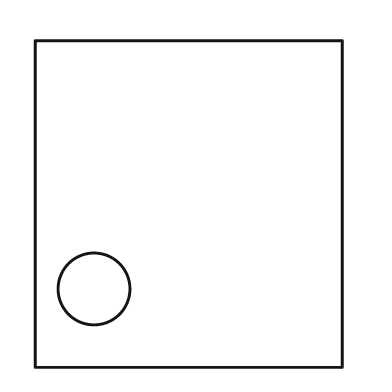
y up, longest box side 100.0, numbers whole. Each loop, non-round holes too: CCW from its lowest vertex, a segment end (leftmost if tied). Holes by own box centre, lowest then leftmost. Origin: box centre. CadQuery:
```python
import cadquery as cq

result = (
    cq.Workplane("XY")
    .moveTo(-47.0, -50.0)
    .lineTo(47.0, -50.0)
    .lineTo(47.0, 50.0)
    .lineTo(-47.0, 50.0)
    .close()
    .moveTo(-29.0, -26.0)
    .circle(11.0)
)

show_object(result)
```